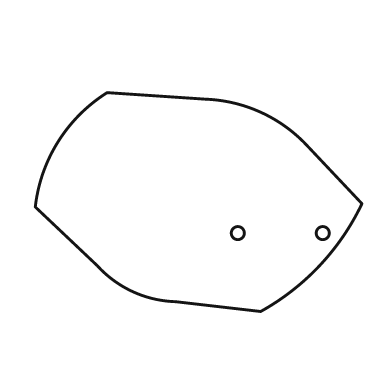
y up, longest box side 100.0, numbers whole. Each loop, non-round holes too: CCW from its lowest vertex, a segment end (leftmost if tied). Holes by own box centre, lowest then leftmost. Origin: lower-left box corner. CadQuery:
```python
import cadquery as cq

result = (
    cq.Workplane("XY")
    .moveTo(69.0, 0.0)
    .threePointArc((87.0, 14.0), (100.0, 33.0))
    .lineTo(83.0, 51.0)
    .threePointArc((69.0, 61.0), (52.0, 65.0))
    .lineTo(22.0, 67.0)
    .threePointArc((7.0, 52.0), (0.0, 32.0))
    .lineTo(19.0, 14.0)
    .threePointArc((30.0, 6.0), (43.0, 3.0))
    .close()
    .moveTo(62.0, 24.0)
    .circle(2.0)
    .moveTo(88.0, 24.0)
    .circle(2.0)
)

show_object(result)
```